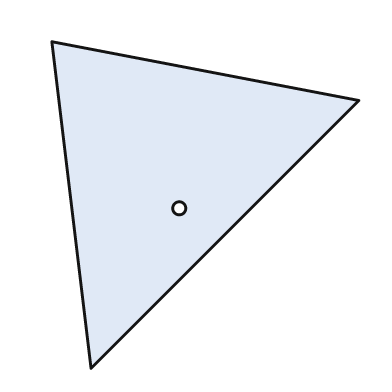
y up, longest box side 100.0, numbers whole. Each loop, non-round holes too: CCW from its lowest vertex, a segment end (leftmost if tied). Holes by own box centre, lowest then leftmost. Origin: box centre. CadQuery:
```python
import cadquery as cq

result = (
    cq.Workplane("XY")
    .moveTo(-35.0, -50.0)
    .lineTo(47.0, 32.0)
    .lineTo(-47.0, 50.0)
    .close()
    .moveTo(-8.0, -1.0)
    .circle(2.0)
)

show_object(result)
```